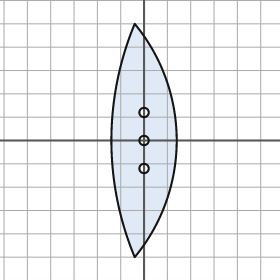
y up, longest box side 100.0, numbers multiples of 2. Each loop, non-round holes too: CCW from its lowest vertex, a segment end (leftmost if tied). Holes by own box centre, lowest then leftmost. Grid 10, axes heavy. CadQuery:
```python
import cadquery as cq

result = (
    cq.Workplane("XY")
    .moveTo(-4.0, -50.0)
    .threePointArc((14.0, 0.0), (-4.0, 50.0))
    .threePointArc((-14.0, 0.0), (-4.0, -50.0))
    .close()
    .moveTo(0.0, -12.0)
    .circle(2.0)
    .moveTo(0.0, 0.0)
    .circle(2.0)
    .moveTo(0.0, 12.0)
    .circle(2.0)
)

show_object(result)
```